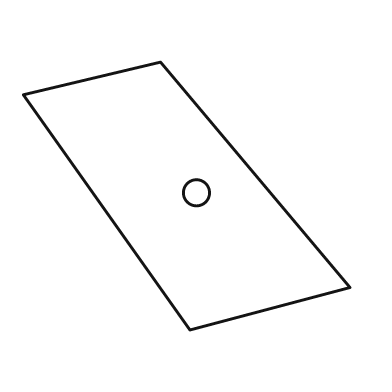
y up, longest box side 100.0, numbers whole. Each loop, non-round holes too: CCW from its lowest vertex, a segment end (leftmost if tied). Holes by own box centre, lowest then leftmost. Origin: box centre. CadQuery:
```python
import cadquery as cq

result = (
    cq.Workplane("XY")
    .moveTo(1.0, -41.0)
    .lineTo(50.0, -28.0)
    .lineTo(-8.0, 41.0)
    .lineTo(-50.0, 31.0)
    .close()
    .moveTo(3.0, 1.0)
    .circle(4.0)
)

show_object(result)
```